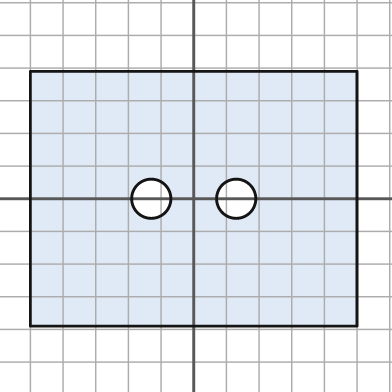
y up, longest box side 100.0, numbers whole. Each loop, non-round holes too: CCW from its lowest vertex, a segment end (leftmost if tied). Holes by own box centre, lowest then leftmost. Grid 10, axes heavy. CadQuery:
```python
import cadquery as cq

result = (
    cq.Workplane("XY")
    .moveTo(-50.0, -39.0)
    .lineTo(50.0, -39.0)
    .lineTo(50.0, 39.0)
    .lineTo(-50.0, 39.0)
    .close()
    .moveTo(-13.0, 0.0)
    .circle(6.0)
    .moveTo(13.0, 0.0)
    .circle(6.0)
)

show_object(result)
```